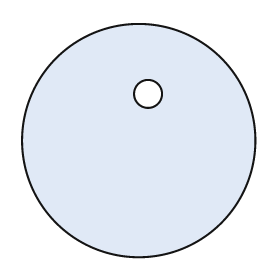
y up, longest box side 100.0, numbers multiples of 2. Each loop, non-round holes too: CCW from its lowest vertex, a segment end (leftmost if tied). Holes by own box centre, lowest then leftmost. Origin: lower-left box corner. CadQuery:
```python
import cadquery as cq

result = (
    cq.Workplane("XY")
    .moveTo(50.0, 50.0)
    .circle(50.0)
    .moveTo(54.0, 70.0)
    .circle(6.0)
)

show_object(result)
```